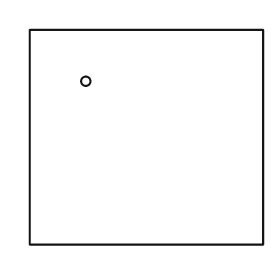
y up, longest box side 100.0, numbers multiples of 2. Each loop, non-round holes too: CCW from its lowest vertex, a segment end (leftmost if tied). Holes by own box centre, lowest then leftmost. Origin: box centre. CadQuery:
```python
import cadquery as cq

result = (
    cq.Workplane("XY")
    .moveTo(-50.0, -46.0)
    .lineTo(50.0, -46.0)
    .lineTo(50.0, 46.0)
    .lineTo(-50.0, 46.0)
    .close()
    .moveTo(-26.0, 24.0)
    .circle(2.0)
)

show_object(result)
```